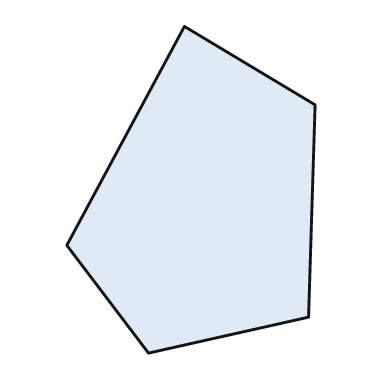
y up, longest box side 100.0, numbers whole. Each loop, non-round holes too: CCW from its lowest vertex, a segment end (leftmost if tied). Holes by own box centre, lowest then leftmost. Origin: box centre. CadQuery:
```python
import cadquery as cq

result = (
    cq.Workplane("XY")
    .moveTo(-13.0, -50.0)
    .lineTo(36.0, -39.0)
    .lineTo(38.0, 26.0)
    .lineTo(-2.0, 50.0)
    .lineTo(-38.0, -17.0)
    .close()
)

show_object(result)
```